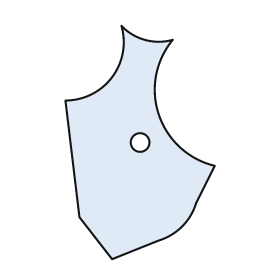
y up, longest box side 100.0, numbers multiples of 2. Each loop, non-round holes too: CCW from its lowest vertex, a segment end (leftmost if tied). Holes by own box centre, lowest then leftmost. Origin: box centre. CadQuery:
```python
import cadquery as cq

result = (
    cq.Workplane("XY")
    .moveTo(-12.0, -50.0)
    .lineTo(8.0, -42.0)
    .threePointArc((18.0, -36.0), (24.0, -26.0))
    .lineTo(32.0, -10.0)
    .threePointArc((8.0, 12.0), (14.0, 44.0))
    .threePointArc((2.0, 44.0), (-8.0, 50.0))
    .threePointArc((-12.0, 28.0), (-32.0, 18.0))
    .lineTo(-26.0, -32.0)
    .close()
    .moveTo(0.0, 0.0)
    .circle(4.0)
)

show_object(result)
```